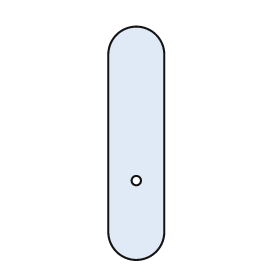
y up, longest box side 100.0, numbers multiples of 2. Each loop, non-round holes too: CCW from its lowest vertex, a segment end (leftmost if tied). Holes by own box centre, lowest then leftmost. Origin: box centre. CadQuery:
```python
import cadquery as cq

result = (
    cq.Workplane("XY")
    .moveTo(-12.0, -38.0)
    .threePointArc((0.0, -50.0), (12.0, -38.0))
    .lineTo(12.0, 38.0)
    .threePointArc((0.0, 50.0), (-12.0, 38.0))
    .close()
    .moveTo(0.0, -16.0)
    .circle(2.0)
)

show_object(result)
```